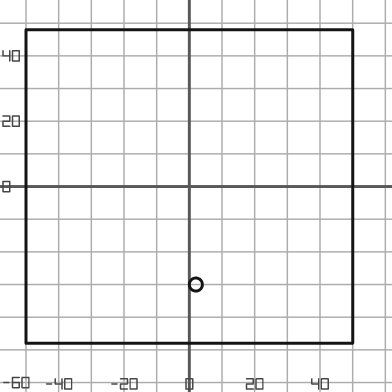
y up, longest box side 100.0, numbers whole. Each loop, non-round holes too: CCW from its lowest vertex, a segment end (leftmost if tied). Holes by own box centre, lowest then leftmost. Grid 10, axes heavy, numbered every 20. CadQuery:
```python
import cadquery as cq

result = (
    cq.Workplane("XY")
    .moveTo(-50.0, -48.0)
    .lineTo(50.0, -48.0)
    .lineTo(50.0, 48.0)
    .lineTo(-50.0, 48.0)
    .close()
    .moveTo(2.0, -30.0)
    .circle(2.0)
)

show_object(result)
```